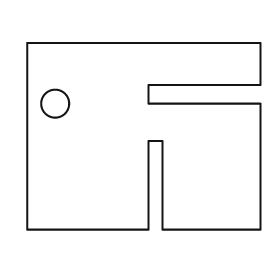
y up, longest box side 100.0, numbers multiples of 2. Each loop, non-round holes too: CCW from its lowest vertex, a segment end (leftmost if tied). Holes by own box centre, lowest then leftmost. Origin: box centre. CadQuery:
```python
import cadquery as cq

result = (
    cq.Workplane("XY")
    .moveTo(-50.0, -40.0)
    .lineTo(2.0, -40.0)
    .lineTo(2.0, -2.0)
    .lineTo(8.0, -2.0)
    .lineTo(8.0, -40.0)
    .lineTo(50.0, -40.0)
    .lineTo(50.0, 14.0)
    .lineTo(2.0, 14.0)
    .lineTo(2.0, 22.0)
    .lineTo(50.0, 22.0)
    .lineTo(50.0, 40.0)
    .lineTo(-50.0, 40.0)
    .close()
    .moveTo(-38.0, 14.0)
    .circle(6.0)
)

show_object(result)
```